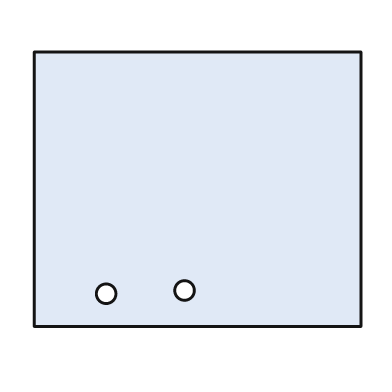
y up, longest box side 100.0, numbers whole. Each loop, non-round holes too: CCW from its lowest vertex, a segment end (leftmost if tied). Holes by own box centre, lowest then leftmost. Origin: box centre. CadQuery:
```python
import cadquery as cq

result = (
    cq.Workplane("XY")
    .moveTo(-50.0, -42.0)
    .lineTo(50.0, -42.0)
    .lineTo(50.0, 42.0)
    .lineTo(-50.0, 42.0)
    .close()
    .moveTo(-28.0, -32.0)
    .circle(3.0)
    .moveTo(-4.0, -31.0)
    .circle(3.0)
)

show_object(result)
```